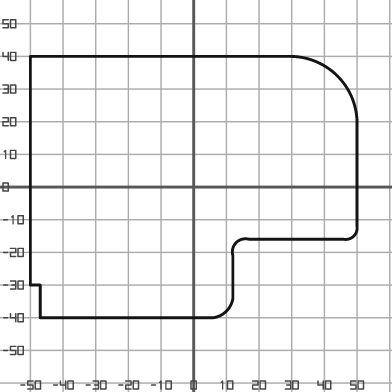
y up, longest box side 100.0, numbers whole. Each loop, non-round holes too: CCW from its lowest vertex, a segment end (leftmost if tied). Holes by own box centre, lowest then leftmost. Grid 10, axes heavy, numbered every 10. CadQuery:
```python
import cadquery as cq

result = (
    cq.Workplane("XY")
    .moveTo(-47.0, -40.0)
    .lineTo(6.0, -40.0)
    .threePointArc((10.0, -38.0), (12.0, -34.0))
    .lineTo(12.0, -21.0)
    .threePointArc((13.0, -17.0), (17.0, -16.0))
    .lineTo(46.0, -16.0)
    .threePointArc((49.0, -15.0), (50.0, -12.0))
    .lineTo(50.0, 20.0)
    .threePointArc((44.0, 34.0), (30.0, 40.0))
    .lineTo(-50.0, 40.0)
    .lineTo(-50.0, -30.0)
    .lineTo(-47.0, -30.0)
    .close()
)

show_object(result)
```